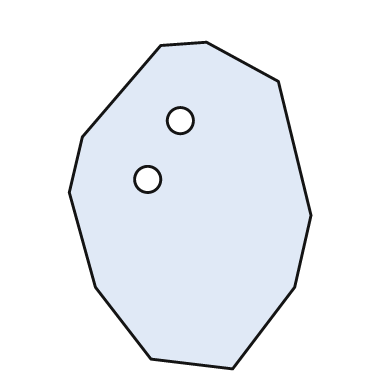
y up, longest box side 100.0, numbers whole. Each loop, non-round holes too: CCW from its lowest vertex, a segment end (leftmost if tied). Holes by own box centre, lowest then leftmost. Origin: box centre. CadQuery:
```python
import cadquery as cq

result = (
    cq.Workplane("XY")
    .moveTo(13.0, -50.0)
    .lineTo(32.0, -25.0)
    .lineTo(37.0, -3.0)
    .lineTo(27.0, 38.0)
    .lineTo(5.0, 50.0)
    .lineTo(-9.0, 49.0)
    .lineTo(-33.0, 21.0)
    .lineTo(-37.0, 4.0)
    .lineTo(-29.0, -25.0)
    .lineTo(-12.0, -47.0)
    .close()
    .moveTo(-13.0, 8.0)
    .circle(4.0)
    .moveTo(-3.0, 26.0)
    .circle(4.0)
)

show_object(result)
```